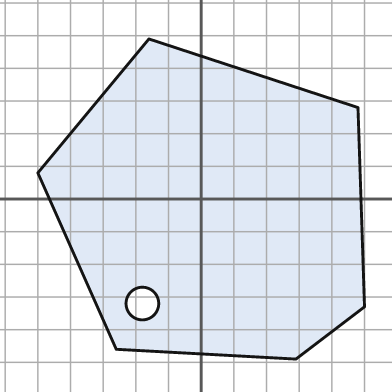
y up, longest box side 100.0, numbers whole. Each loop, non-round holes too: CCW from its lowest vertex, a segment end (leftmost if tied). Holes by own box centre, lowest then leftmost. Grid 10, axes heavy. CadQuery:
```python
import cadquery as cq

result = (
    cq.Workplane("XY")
    .moveTo(29.0, -49.0)
    .lineTo(50.0, -33.0)
    .lineTo(48.0, 28.0)
    .lineTo(-16.0, 49.0)
    .lineTo(-50.0, 8.0)
    .lineTo(-26.0, -46.0)
    .close()
    .moveTo(-18.0, -32.0)
    .circle(5.0)
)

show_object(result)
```